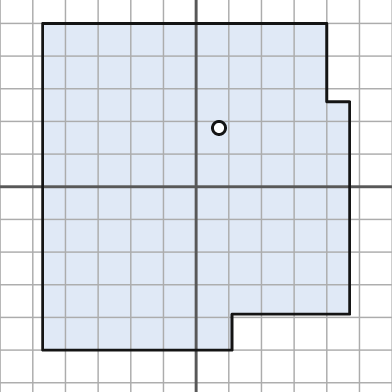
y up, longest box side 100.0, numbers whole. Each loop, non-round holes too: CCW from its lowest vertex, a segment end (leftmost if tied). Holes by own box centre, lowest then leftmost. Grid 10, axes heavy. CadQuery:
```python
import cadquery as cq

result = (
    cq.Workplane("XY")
    .moveTo(-47.0, -50.0)
    .lineTo(11.0, -50.0)
    .lineTo(11.0, -39.0)
    .lineTo(47.0, -39.0)
    .lineTo(47.0, 26.0)
    .lineTo(40.0, 26.0)
    .lineTo(40.0, 50.0)
    .lineTo(-47.0, 50.0)
    .close()
    .moveTo(7.0, 18.0)
    .circle(2.0)
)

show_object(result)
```